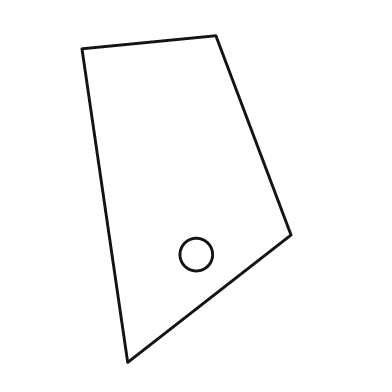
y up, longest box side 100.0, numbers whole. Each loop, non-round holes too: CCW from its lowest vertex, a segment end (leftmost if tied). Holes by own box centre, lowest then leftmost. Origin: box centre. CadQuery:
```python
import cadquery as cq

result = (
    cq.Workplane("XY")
    .moveTo(-18.0, -50.0)
    .lineTo(32.0, -11.0)
    .lineTo(9.0, 50.0)
    .lineTo(-32.0, 46.0)
    .close()
    .moveTo(3.0, -17.0)
    .circle(5.0)
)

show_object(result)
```